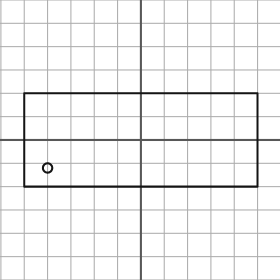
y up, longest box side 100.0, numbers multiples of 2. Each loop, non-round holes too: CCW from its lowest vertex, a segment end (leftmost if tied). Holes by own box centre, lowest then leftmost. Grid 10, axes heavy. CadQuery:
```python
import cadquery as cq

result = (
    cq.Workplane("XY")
    .moveTo(-50.0, -20.0)
    .lineTo(50.0, -20.0)
    .lineTo(50.0, 20.0)
    .lineTo(-50.0, 20.0)
    .close()
    .moveTo(-40.0, -12.0)
    .circle(2.0)
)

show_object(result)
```